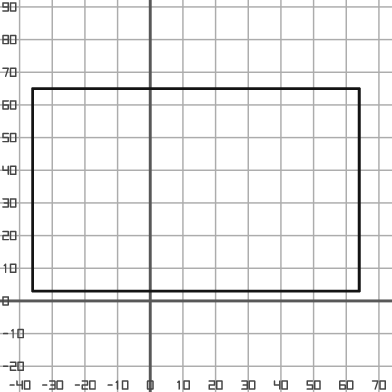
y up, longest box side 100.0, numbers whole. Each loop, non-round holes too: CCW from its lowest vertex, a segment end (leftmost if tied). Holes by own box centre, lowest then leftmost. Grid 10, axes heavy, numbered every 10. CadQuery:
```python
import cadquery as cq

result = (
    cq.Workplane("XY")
    .moveTo(-36.0, 3.0)
    .lineTo(64.0, 3.0)
    .lineTo(64.0, 65.0)
    .lineTo(-36.0, 65.0)
    .close()
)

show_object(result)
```